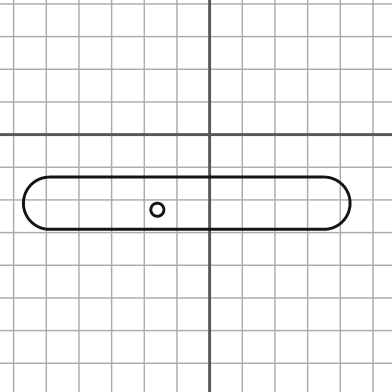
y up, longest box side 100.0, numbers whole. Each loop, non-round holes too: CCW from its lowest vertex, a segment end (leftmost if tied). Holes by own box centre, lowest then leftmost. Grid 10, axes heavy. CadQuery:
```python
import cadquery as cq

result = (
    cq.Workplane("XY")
    .moveTo(-49.0, -29.0)
    .lineTo(35.0, -29.0)
    .threePointArc((43.0, -21.0), (35.0, -13.0))
    .lineTo(-49.0, -13.0)
    .threePointArc((-57.0, -21.0), (-49.0, -29.0))
    .close()
    .moveTo(-16.0, -23.0)
    .circle(2.0)
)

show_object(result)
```